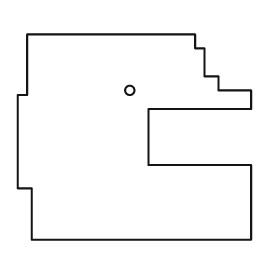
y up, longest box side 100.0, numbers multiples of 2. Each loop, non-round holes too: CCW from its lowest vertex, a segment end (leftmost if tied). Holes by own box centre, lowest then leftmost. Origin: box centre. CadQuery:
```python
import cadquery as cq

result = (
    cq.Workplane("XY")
    .moveTo(-44.0, -44.0)
    .lineTo(50.0, -44.0)
    .lineTo(50.0, -12.0)
    .lineTo(6.0, -12.0)
    .lineTo(6.0, 12.0)
    .lineTo(50.0, 12.0)
    .lineTo(50.0, 20.0)
    .lineTo(36.0, 20.0)
    .lineTo(36.0, 26.0)
    .lineTo(30.0, 26.0)
    .lineTo(30.0, 38.0)
    .lineTo(26.0, 38.0)
    .lineTo(26.0, 44.0)
    .lineTo(-46.0, 44.0)
    .lineTo(-46.0, 18.0)
    .lineTo(-50.0, 18.0)
    .lineTo(-50.0, -22.0)
    .lineTo(-44.0, -22.0)
    .close()
    .moveTo(-2.0, 20.0)
    .circle(2.0)
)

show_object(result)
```